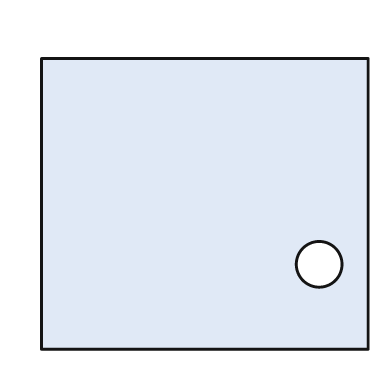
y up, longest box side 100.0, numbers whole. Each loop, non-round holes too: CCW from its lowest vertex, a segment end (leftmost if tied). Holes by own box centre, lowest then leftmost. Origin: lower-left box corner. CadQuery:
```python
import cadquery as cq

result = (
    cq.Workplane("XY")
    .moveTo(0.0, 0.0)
    .lineTo(100.0, 0.0)
    .lineTo(100.0, 89.0)
    .lineTo(0.0, 89.0)
    .close()
    .moveTo(85.0, 26.0)
    .circle(7.0)
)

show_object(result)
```